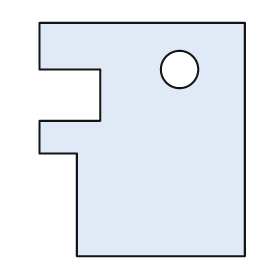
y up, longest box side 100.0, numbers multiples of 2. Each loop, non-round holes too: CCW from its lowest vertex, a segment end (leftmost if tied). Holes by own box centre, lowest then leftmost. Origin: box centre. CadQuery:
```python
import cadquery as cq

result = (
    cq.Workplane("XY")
    .moveTo(-28.0, -50.0)
    .lineTo(44.0, -50.0)
    .lineTo(44.0, 50.0)
    .lineTo(-44.0, 50.0)
    .lineTo(-44.0, 30.0)
    .lineTo(-18.0, 30.0)
    .lineTo(-18.0, 8.0)
    .lineTo(-44.0, 8.0)
    .lineTo(-44.0, -6.0)
    .lineTo(-28.0, -6.0)
    .close()
    .moveTo(16.0, 30.0)
    .circle(8.0)
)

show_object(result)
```